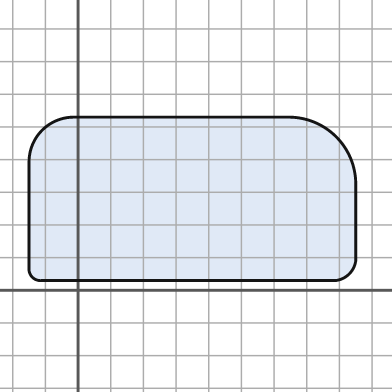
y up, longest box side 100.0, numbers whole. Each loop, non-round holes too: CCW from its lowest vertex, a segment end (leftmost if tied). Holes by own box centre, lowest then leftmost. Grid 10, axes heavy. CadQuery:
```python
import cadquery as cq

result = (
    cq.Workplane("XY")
    .moveTo(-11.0, 3.0)
    .lineTo(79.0, 3.0)
    .threePointArc((83.0, 5.0), (85.0, 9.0))
    .lineTo(85.0, 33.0)
    .threePointArc((79.0, 47.0), (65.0, 53.0))
    .lineTo(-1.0, 53.0)
    .threePointArc((-11.0, 49.0), (-15.0, 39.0))
    .lineTo(-15.0, 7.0)
    .threePointArc((-14.0, 4.0), (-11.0, 3.0))
    .close()
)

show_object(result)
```